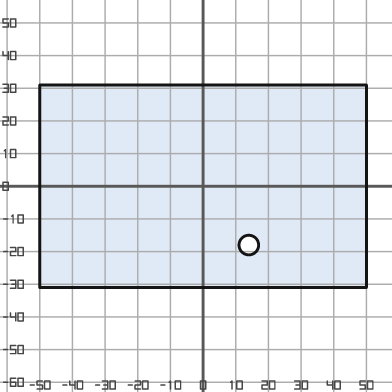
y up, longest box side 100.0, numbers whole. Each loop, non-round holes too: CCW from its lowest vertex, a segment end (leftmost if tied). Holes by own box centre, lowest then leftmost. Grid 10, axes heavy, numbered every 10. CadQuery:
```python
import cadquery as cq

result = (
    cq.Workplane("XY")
    .moveTo(-50.0, -31.0)
    .lineTo(50.0, -31.0)
    .lineTo(50.0, 31.0)
    .lineTo(-50.0, 31.0)
    .close()
    .moveTo(14.0, -18.0)
    .circle(3.0)
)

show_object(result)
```